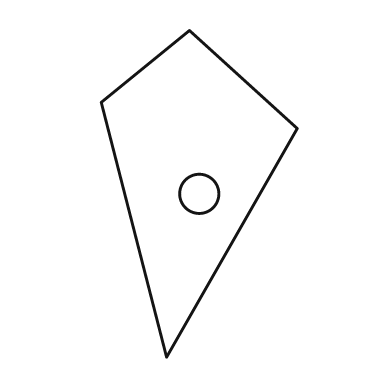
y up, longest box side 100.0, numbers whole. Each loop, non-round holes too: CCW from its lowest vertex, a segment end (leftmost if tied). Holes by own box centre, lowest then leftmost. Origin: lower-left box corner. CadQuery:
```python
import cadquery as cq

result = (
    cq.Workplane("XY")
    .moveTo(20.0, 0.0)
    .lineTo(60.0, 70.0)
    .lineTo(27.0, 100.0)
    .lineTo(0.0, 78.0)
    .close()
    .moveTo(30.0, 50.0)
    .circle(6.0)
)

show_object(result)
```